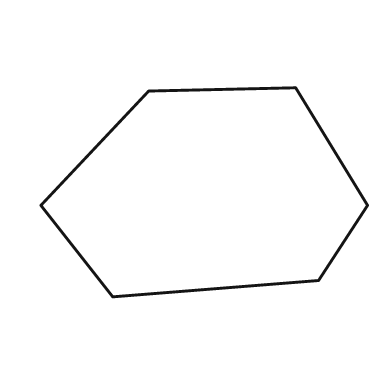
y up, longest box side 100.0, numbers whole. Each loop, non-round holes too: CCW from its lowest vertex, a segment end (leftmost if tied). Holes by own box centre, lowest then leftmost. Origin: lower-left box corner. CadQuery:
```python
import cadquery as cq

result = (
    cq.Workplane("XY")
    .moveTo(22.0, 0.0)
    .lineTo(85.0, 5.0)
    .lineTo(100.0, 28.0)
    .lineTo(78.0, 64.0)
    .lineTo(33.0, 63.0)
    .lineTo(0.0, 28.0)
    .close()
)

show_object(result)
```